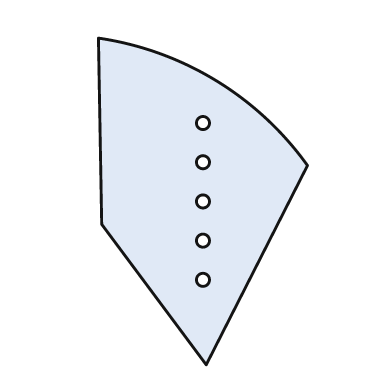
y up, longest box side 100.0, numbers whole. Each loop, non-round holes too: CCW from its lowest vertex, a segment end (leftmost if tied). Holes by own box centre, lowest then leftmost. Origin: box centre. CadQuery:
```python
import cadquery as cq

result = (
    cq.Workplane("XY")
    .moveTo(1.0, -50.0)
    .lineTo(32.0, 11.0)
    .threePointArc((4.0, 37.0), (-32.0, 50.0))
    .lineTo(-31.0, -7.0)
    .close()
    .moveTo(0.0, -24.0)
    .circle(2.0)
    .moveTo(0.0, -12.0)
    .circle(2.0)
    .moveTo(0.0, 0.0)
    .circle(2.0)
    .moveTo(0.0, 12.0)
    .circle(2.0)
    .moveTo(0.0, 24.0)
    .circle(2.0)
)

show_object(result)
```